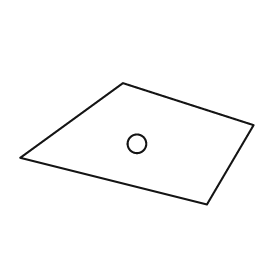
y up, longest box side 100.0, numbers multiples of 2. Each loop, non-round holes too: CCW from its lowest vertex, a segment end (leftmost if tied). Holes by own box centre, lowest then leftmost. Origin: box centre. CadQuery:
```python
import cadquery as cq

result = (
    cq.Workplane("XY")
    .moveTo(30.0, -26.0)
    .lineTo(50.0, 8.0)
    .lineTo(-6.0, 26.0)
    .lineTo(-50.0, -6.0)
    .close()
    .moveTo(0.0, 0.0)
    .circle(4.0)
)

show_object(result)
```